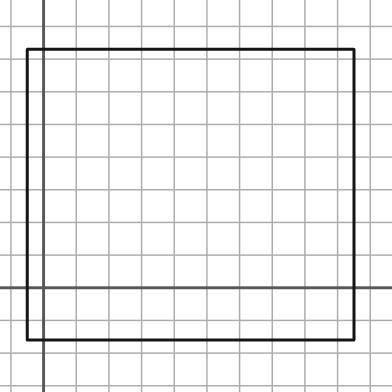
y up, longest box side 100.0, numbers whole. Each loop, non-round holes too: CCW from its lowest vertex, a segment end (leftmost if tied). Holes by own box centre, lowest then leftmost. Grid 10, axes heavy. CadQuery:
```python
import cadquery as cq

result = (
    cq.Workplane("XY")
    .moveTo(-5.0, -16.0)
    .lineTo(95.0, -16.0)
    .lineTo(95.0, 73.0)
    .lineTo(-5.0, 73.0)
    .close()
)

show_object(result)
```